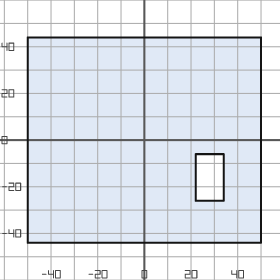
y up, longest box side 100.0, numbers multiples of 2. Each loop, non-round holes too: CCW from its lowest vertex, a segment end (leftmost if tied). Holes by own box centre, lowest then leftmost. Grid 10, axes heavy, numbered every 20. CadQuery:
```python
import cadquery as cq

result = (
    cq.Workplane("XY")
    .moveTo(-50.0, -44.0)
    .lineTo(50.0, -44.0)
    .lineTo(50.0, 44.0)
    .lineTo(-50.0, 44.0)
    .close()
    .moveTo(22.0, -26.0)
    .lineTo(34.0, -26.0)
    .lineTo(34.0, -6.0)
    .lineTo(22.0, -6.0)
    .close()
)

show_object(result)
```